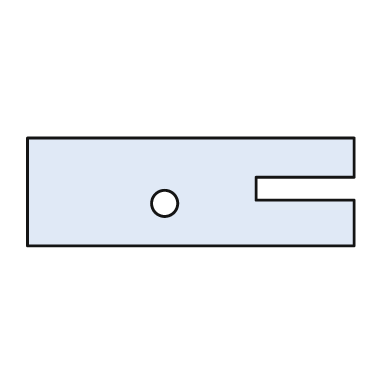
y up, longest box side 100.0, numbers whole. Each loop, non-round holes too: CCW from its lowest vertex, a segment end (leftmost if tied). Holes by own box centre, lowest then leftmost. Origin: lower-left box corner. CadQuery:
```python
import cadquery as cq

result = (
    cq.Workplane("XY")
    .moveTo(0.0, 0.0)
    .lineTo(100.0, 0.0)
    .lineTo(100.0, 14.0)
    .lineTo(70.0, 14.0)
    .lineTo(70.0, 21.0)
    .lineTo(100.0, 21.0)
    .lineTo(100.0, 33.0)
    .lineTo(0.0, 33.0)
    .close()
    .moveTo(42.0, 13.0)
    .circle(4.0)
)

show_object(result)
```